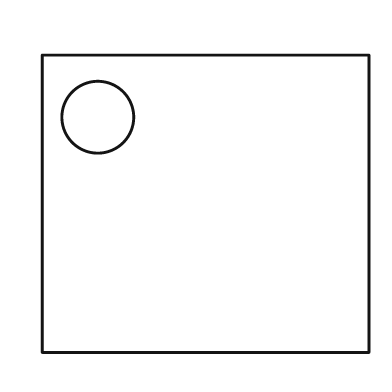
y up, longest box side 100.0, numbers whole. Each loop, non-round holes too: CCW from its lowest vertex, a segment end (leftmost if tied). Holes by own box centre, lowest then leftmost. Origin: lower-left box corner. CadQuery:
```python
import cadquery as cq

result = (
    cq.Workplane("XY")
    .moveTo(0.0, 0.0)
    .lineTo(100.0, 0.0)
    .lineTo(100.0, 91.0)
    .lineTo(0.0, 91.0)
    .close()
    .moveTo(17.0, 72.0)
    .circle(11.0)
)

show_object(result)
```